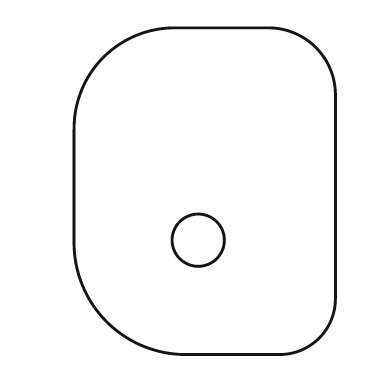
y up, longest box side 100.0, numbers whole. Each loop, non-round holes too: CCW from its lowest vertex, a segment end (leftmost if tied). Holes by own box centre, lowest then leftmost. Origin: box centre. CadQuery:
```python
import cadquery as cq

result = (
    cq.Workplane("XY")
    .moveTo(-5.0, -50.0)
    .lineTo(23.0, -50.0)
    .threePointArc((35.0, -45.0), (40.0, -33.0))
    .lineTo(40.0, 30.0)
    .threePointArc((34.0, 44.0), (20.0, 50.0))
    .lineTo(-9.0, 50.0)
    .threePointArc((-31.0, 41.0), (-40.0, 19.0))
    .lineTo(-40.0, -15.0)
    .threePointArc((-30.0, -40.0), (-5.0, -50.0))
    .close()
    .moveTo(-2.0, -15.0)
    .circle(8.0)
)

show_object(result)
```